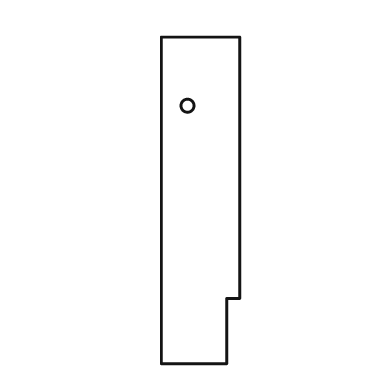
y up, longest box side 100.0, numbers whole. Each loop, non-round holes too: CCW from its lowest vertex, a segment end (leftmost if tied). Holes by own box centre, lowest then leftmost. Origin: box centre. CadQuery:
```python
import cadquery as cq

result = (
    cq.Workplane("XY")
    .moveTo(-12.0, -50.0)
    .lineTo(8.0, -50.0)
    .lineTo(8.0, -30.0)
    .lineTo(12.0, -30.0)
    .lineTo(12.0, 50.0)
    .lineTo(-12.0, 50.0)
    .close()
    .moveTo(-4.0, 29.0)
    .circle(2.0)
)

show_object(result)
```